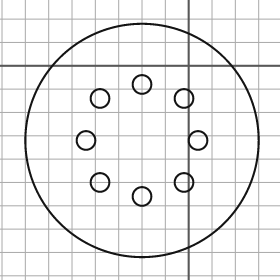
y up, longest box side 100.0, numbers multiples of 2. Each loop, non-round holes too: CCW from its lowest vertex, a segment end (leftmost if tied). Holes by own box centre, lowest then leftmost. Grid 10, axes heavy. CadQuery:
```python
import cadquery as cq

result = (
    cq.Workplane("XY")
    .moveTo(-20.0, -32.0)
    .circle(50.0)
    .moveTo(-20.0, -56.0)
    .circle(4.0)
    .moveTo(-38.0, -50.0)
    .circle(4.0)
    .moveTo(-2.0, -50.0)
    .circle(4.0)
    .moveTo(-44.0, -32.0)
    .circle(4.0)
    .moveTo(4.0, -32.0)
    .circle(4.0)
    .moveTo(-38.0, -14.0)
    .circle(4.0)
    .moveTo(-2.0, -14.0)
    .circle(4.0)
    .moveTo(-20.0, -8.0)
    .circle(4.0)
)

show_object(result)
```